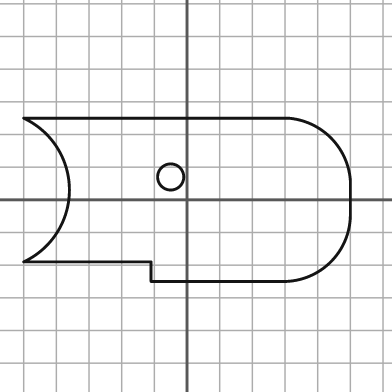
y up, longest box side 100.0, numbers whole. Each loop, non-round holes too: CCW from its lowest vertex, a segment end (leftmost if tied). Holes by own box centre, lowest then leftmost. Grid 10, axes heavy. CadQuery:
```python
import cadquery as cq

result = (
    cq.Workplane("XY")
    .moveTo(-11.0, -25.0)
    .lineTo(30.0, -25.0)
    .threePointArc((44.0, -19.0), (50.0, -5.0))
    .lineTo(50.0, 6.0)
    .threePointArc((44.0, 19.0), (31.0, 25.0))
    .lineTo(-50.0, 25.0)
    .threePointArc((-36.0, 3.0), (-50.0, -19.0))
    .lineTo(-11.0, -19.0)
    .close()
    .moveTo(-5.0, 7.0)
    .circle(4.0)
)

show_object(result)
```